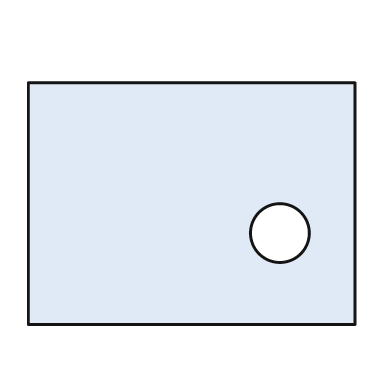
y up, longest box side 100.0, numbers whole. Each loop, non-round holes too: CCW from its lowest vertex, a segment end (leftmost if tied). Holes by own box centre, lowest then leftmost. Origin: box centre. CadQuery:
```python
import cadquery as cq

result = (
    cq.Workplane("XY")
    .moveTo(-50.0, -37.0)
    .lineTo(50.0, -37.0)
    .lineTo(50.0, 37.0)
    .lineTo(-50.0, 37.0)
    .close()
    .moveTo(27.0, -9.0)
    .circle(9.0)
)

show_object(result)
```